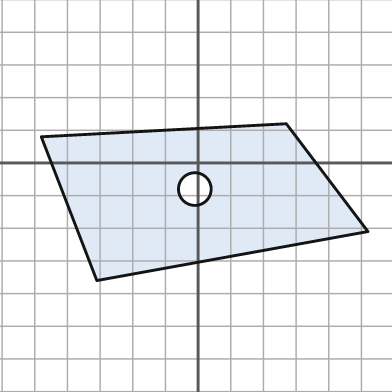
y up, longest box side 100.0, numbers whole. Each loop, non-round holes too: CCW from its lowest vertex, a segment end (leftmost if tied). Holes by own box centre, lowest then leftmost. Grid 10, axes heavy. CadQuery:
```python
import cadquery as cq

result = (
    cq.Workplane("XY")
    .moveTo(-31.0, -36.0)
    .lineTo(52.0, -21.0)
    .lineTo(27.0, 12.0)
    .lineTo(-48.0, 8.0)
    .close()
    .moveTo(-1.0, -8.0)
    .circle(5.0)
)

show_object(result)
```